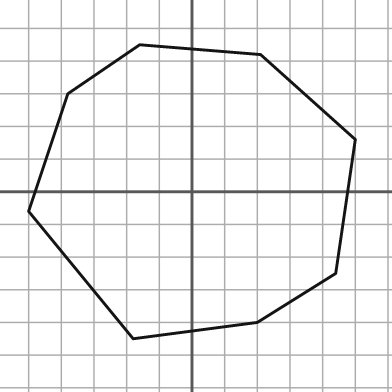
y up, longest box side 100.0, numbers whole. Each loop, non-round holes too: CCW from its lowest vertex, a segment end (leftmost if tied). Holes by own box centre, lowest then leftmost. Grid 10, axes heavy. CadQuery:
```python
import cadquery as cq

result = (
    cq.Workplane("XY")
    .moveTo(-18.0, -45.0)
    .lineTo(20.0, -40.0)
    .lineTo(44.0, -25.0)
    .lineTo(50.0, 16.0)
    .lineTo(21.0, 42.0)
    .lineTo(-16.0, 45.0)
    .lineTo(-38.0, 30.0)
    .lineTo(-50.0, -6.0)
    .close()
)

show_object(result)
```